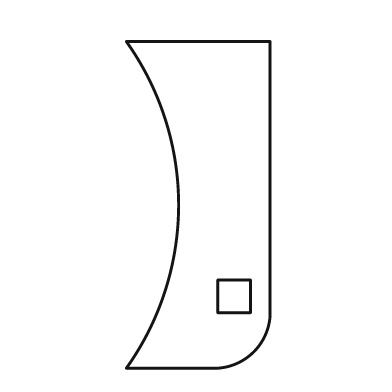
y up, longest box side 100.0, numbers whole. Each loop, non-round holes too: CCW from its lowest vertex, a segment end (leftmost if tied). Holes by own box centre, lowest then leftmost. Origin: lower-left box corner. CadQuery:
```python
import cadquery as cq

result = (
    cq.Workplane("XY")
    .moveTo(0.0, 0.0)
    .lineTo(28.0, 0.0)
    .threePointArc((39.0, 5.0), (44.0, 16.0))
    .lineTo(44.0, 100.0)
    .lineTo(0.0, 100.0)
    .threePointArc((16.0, 50.0), (0.0, 0.0))
    .close()
    .moveTo(28.0, 17.0)
    .lineTo(38.0, 17.0)
    .lineTo(38.0, 27.0)
    .lineTo(28.0, 27.0)
    .close()
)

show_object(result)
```